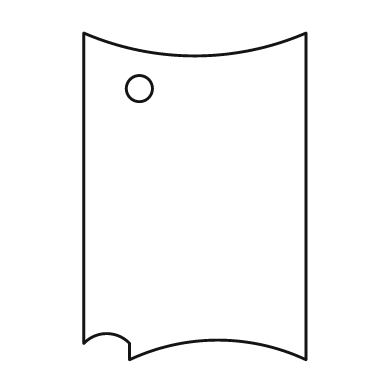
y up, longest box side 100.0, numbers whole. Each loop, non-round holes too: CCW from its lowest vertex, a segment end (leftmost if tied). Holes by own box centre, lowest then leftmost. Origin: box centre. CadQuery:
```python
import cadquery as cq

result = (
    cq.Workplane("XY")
    .moveTo(-20.0, -50.0)
    .threePointArc((7.0, -44.0), (34.0, -50.0))
    .lineTo(34.0, 50.0)
    .threePointArc((0.0, 43.0), (-34.0, 50.0))
    .lineTo(-34.0, -45.0)
    .threePointArc((-27.0, -42.0), (-20.0, -45.0))
    .close()
    .moveTo(-17.0, 33.0)
    .circle(4.0)
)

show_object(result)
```